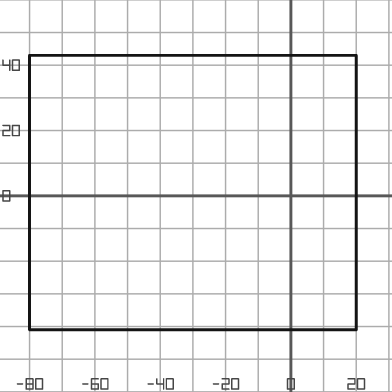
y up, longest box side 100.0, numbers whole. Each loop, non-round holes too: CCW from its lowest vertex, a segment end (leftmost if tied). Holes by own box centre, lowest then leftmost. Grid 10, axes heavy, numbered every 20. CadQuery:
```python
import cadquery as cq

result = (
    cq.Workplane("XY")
    .moveTo(-80.0, -41.0)
    .lineTo(20.0, -41.0)
    .lineTo(20.0, 43.0)
    .lineTo(-80.0, 43.0)
    .close()
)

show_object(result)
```